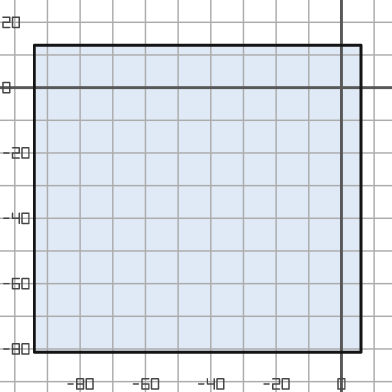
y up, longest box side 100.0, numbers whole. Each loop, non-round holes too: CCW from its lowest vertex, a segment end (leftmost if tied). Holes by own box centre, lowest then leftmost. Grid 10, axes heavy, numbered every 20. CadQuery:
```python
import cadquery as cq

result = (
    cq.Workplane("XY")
    .moveTo(-94.0, -81.0)
    .lineTo(6.0, -81.0)
    .lineTo(6.0, 13.0)
    .lineTo(-94.0, 13.0)
    .close()
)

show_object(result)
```